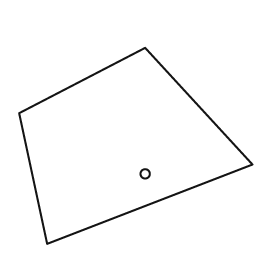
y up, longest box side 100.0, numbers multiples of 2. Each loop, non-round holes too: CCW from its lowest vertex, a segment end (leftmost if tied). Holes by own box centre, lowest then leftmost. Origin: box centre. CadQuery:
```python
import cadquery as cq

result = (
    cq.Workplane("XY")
    .moveTo(-38.0, -42.0)
    .lineTo(50.0, -8.0)
    .lineTo(4.0, 42.0)
    .lineTo(-50.0, 14.0)
    .close()
    .moveTo(4.0, -12.0)
    .circle(2.0)
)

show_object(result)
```